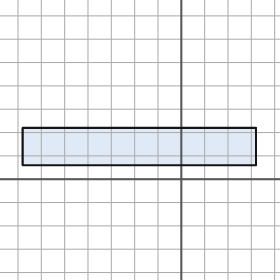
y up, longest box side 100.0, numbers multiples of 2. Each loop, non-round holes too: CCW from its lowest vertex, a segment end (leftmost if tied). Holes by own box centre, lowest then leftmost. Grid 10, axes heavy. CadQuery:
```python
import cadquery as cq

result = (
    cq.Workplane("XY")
    .moveTo(-68.0, 6.0)
    .lineTo(32.0, 6.0)
    .lineTo(32.0, 22.0)
    .lineTo(-68.0, 22.0)
    .close()
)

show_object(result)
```